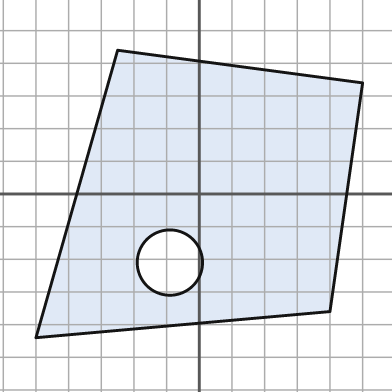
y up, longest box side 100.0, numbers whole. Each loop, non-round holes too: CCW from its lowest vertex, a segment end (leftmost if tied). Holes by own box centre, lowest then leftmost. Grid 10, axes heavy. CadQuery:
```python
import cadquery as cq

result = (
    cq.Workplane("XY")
    .moveTo(-50.0, -44.0)
    .lineTo(40.0, -36.0)
    .lineTo(50.0, 34.0)
    .lineTo(-25.0, 44.0)
    .close()
    .moveTo(-9.0, -21.0)
    .circle(10.0)
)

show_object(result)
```